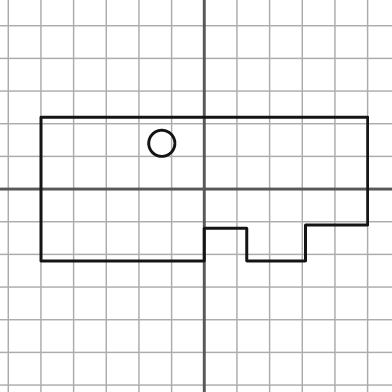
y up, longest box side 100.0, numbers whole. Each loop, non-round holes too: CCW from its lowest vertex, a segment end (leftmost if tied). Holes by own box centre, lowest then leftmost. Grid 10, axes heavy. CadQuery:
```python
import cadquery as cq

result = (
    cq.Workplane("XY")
    .moveTo(-50.0, -22.0)
    .lineTo(0.0, -22.0)
    .lineTo(0.0, -12.0)
    .lineTo(13.0, -12.0)
    .lineTo(13.0, -22.0)
    .lineTo(31.0, -22.0)
    .lineTo(31.0, -11.0)
    .lineTo(50.0, -11.0)
    .lineTo(50.0, 22.0)
    .lineTo(-50.0, 22.0)
    .close()
    .moveTo(-13.0, 14.0)
    .circle(4.0)
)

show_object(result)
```